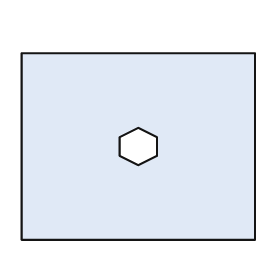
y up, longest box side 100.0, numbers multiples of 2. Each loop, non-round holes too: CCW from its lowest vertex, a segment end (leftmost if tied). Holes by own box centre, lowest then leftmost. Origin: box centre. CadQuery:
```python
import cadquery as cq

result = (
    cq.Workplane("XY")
    .moveTo(-50.0, -40.0)
    .lineTo(50.0, -40.0)
    .lineTo(50.0, 40.0)
    .lineTo(-50.0, 40.0)
    .close()
    .moveTo(0.0, -8.0)
    .lineTo(8.0, -4.0)
    .lineTo(8.0, 4.0)
    .lineTo(0.0, 8.0)
    .lineTo(-8.0, 4.0)
    .lineTo(-8.0, -4.0)
    .close()
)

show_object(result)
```